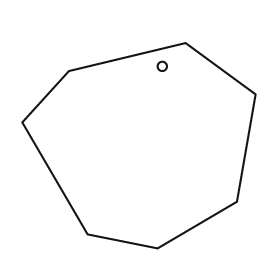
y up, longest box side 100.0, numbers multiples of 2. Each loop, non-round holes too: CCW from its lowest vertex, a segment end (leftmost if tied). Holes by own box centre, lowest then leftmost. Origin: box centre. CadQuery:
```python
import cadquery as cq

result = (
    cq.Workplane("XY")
    .moveTo(8.0, -44.0)
    .lineTo(42.0, -24.0)
    .lineTo(50.0, 22.0)
    .lineTo(20.0, 44.0)
    .lineTo(-30.0, 32.0)
    .lineTo(-50.0, 10.0)
    .lineTo(-22.0, -38.0)
    .close()
    .moveTo(10.0, 34.0)
    .circle(2.0)
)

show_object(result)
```